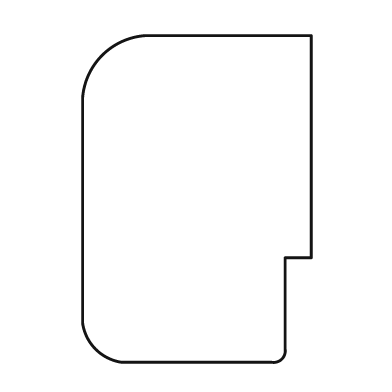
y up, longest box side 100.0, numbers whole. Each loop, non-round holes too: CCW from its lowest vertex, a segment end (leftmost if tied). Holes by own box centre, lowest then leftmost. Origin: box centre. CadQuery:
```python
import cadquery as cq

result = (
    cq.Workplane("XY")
    .moveTo(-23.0, -50.0)
    .lineTo(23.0, -50.0)
    .threePointArc((26.0, -49.0), (27.0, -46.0))
    .lineTo(27.0, -18.0)
    .lineTo(35.0, -18.0)
    .lineTo(35.0, 50.0)
    .lineTo(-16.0, 50.0)
    .threePointArc((-29.0, 44.0), (-35.0, 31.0))
    .lineTo(-35.0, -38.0)
    .threePointArc((-31.0, -46.0), (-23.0, -50.0))
    .close()
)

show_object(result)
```